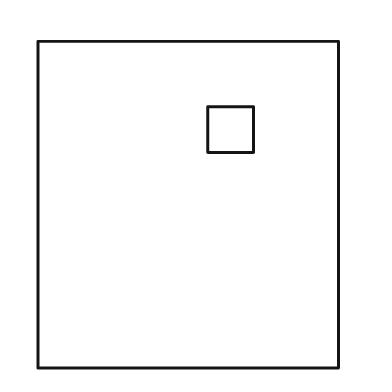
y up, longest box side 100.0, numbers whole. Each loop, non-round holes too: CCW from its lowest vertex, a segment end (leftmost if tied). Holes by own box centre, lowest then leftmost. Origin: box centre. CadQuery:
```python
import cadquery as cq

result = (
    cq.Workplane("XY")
    .moveTo(-46.0, -50.0)
    .lineTo(46.0, -50.0)
    .lineTo(46.0, 50.0)
    .lineTo(-46.0, 50.0)
    .close()
    .moveTo(6.0, 16.0)
    .lineTo(20.0, 16.0)
    .lineTo(20.0, 30.0)
    .lineTo(6.0, 30.0)
    .close()
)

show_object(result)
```